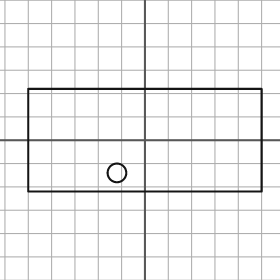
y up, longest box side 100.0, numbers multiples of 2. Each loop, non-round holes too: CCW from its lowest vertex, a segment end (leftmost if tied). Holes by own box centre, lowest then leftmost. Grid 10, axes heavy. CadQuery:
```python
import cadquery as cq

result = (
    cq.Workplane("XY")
    .moveTo(-50.0, -22.0)
    .lineTo(50.0, -22.0)
    .lineTo(50.0, 22.0)
    .lineTo(-50.0, 22.0)
    .close()
    .moveTo(-12.0, -14.0)
    .circle(4.0)
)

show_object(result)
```